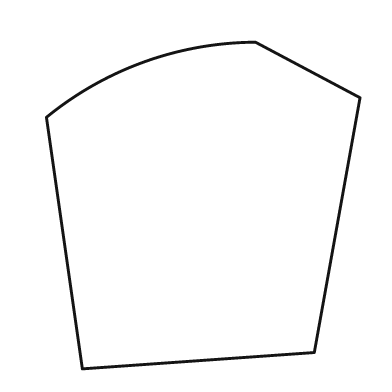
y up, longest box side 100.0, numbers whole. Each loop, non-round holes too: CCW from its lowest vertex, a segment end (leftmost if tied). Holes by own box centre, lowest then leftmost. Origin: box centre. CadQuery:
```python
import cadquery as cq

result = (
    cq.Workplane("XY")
    .moveTo(-37.0, -50.0)
    .lineTo(34.0, -45.0)
    .lineTo(48.0, 33.0)
    .lineTo(16.0, 50.0)
    .threePointArc((-18.0, 44.0), (-48.0, 27.0))
    .close()
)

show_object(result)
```